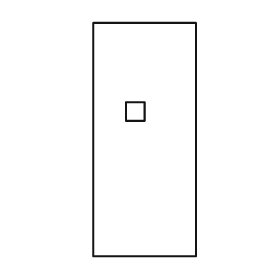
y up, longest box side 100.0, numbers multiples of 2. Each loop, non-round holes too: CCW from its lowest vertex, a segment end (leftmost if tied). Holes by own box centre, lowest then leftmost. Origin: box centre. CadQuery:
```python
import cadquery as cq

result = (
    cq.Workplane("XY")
    .moveTo(-22.0, -50.0)
    .lineTo(22.0, -50.0)
    .lineTo(22.0, 50.0)
    .lineTo(-22.0, 50.0)
    .close()
    .moveTo(-8.0, 8.0)
    .lineTo(0.0, 8.0)
    .lineTo(0.0, 16.0)
    .lineTo(-8.0, 16.0)
    .close()
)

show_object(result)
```